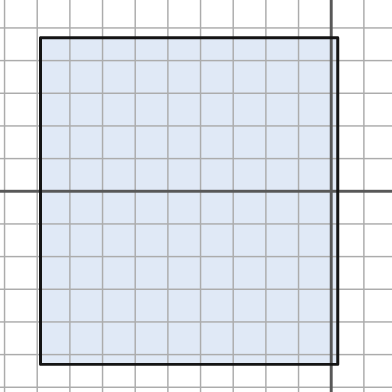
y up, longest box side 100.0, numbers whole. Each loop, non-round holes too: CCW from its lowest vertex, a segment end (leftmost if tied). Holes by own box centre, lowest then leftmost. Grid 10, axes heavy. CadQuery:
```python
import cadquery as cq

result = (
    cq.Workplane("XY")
    .moveTo(-89.0, -53.0)
    .lineTo(2.0, -53.0)
    .lineTo(2.0, 47.0)
    .lineTo(-89.0, 47.0)
    .close()
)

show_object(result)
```